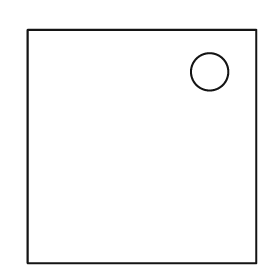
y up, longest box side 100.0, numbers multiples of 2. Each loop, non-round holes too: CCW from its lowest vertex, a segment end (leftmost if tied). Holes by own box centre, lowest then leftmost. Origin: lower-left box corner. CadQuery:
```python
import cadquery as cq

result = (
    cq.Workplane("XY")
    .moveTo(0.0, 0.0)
    .lineTo(98.0, 0.0)
    .lineTo(98.0, 100.0)
    .lineTo(0.0, 100.0)
    .close()
    .moveTo(78.0, 82.0)
    .circle(8.0)
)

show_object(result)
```